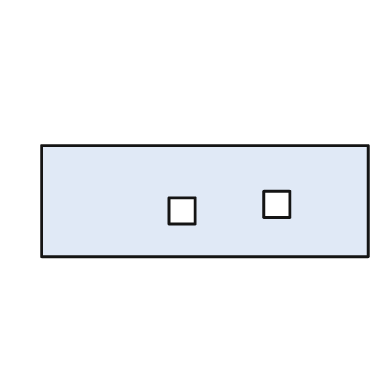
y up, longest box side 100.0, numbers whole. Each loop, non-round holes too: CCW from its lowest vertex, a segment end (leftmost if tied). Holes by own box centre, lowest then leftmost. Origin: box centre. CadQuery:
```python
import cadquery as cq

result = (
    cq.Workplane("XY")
    .moveTo(-50.0, -17.0)
    .lineTo(50.0, -17.0)
    .lineTo(50.0, 17.0)
    .lineTo(-50.0, 17.0)
    .close()
    .moveTo(-11.0, -7.0)
    .lineTo(-3.0, -7.0)
    .lineTo(-3.0, 1.0)
    .lineTo(-11.0, 1.0)
    .close()
    .moveTo(18.0, -5.0)
    .lineTo(26.0, -5.0)
    .lineTo(26.0, 3.0)
    .lineTo(18.0, 3.0)
    .close()
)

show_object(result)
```